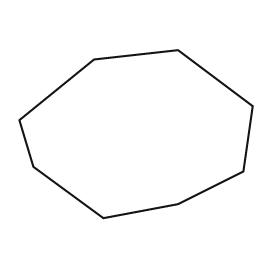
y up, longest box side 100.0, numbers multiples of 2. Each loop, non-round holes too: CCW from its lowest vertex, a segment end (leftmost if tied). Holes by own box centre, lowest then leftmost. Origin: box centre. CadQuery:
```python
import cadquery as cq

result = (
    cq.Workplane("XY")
    .moveTo(-14.0, -36.0)
    .lineTo(18.0, -30.0)
    .lineTo(46.0, -16.0)
    .lineTo(50.0, 12.0)
    .lineTo(18.0, 36.0)
    .lineTo(-18.0, 32.0)
    .lineTo(-50.0, 6.0)
    .lineTo(-44.0, -14.0)
    .close()
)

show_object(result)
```